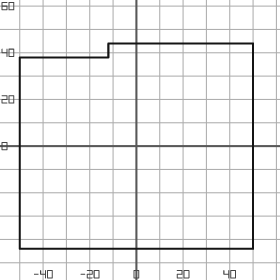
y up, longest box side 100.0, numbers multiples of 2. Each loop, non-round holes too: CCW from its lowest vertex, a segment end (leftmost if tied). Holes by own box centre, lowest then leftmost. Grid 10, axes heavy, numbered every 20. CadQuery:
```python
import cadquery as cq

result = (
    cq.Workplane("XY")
    .moveTo(-50.0, -44.0)
    .lineTo(50.0, -44.0)
    .lineTo(50.0, 44.0)
    .lineTo(-12.0, 44.0)
    .lineTo(-12.0, 38.0)
    .lineTo(-50.0, 38.0)
    .close()
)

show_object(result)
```